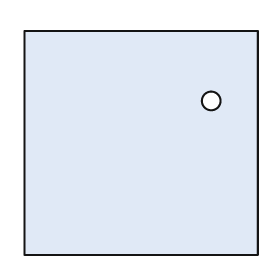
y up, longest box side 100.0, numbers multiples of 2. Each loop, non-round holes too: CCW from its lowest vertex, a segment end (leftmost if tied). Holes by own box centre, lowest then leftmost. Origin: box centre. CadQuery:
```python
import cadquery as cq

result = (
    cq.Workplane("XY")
    .moveTo(-50.0, -48.0)
    .lineTo(50.0, -48.0)
    .lineTo(50.0, 48.0)
    .lineTo(-50.0, 48.0)
    .close()
    .moveTo(30.0, 18.0)
    .circle(4.0)
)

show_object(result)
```